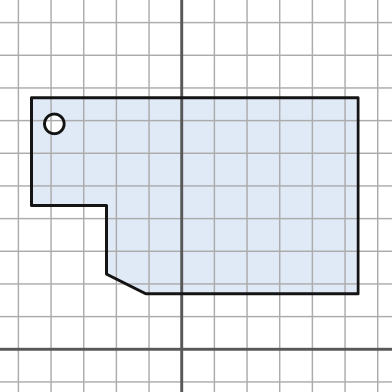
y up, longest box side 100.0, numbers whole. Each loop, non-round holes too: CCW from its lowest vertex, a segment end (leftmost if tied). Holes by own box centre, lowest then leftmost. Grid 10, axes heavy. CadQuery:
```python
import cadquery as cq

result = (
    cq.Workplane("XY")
    .moveTo(-11.0, 17.0)
    .lineTo(54.0, 17.0)
    .lineTo(54.0, 77.0)
    .lineTo(-46.0, 77.0)
    .lineTo(-46.0, 44.0)
    .lineTo(-23.0, 44.0)
    .lineTo(-23.0, 23.0)
    .close()
    .moveTo(-39.0, 69.0)
    .circle(3.0)
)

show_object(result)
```